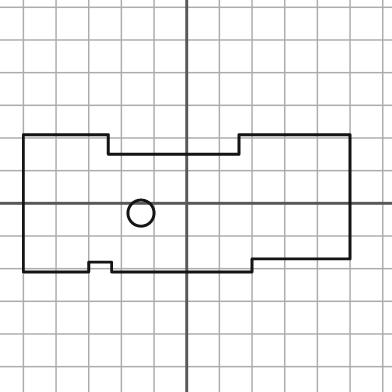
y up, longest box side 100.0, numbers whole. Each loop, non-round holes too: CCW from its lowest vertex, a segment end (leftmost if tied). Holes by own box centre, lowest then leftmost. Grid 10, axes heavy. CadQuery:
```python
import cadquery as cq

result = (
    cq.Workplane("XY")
    .moveTo(-50.0, -21.0)
    .lineTo(-30.0, -21.0)
    .lineTo(-30.0, -18.0)
    .lineTo(-23.0, -18.0)
    .lineTo(-23.0, -21.0)
    .lineTo(20.0, -21.0)
    .lineTo(20.0, -17.0)
    .lineTo(50.0, -17.0)
    .lineTo(50.0, 21.0)
    .lineTo(16.0, 21.0)
    .lineTo(16.0, 15.0)
    .lineTo(-24.0, 15.0)
    .lineTo(-24.0, 21.0)
    .lineTo(-50.0, 21.0)
    .close()
    .moveTo(-14.0, -3.0)
    .circle(4.0)
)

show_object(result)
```